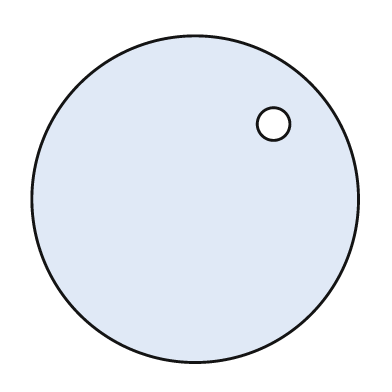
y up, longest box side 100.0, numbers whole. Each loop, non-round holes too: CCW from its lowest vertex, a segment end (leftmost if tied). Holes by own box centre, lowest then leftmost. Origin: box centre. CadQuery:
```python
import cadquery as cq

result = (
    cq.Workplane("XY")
    .moveTo(0.0, 0.0)
    .circle(50.0)
    .moveTo(24.0, 23.0)
    .circle(5.0)
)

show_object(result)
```